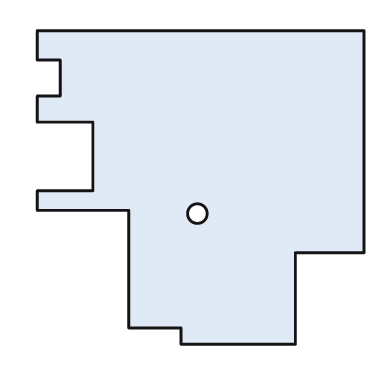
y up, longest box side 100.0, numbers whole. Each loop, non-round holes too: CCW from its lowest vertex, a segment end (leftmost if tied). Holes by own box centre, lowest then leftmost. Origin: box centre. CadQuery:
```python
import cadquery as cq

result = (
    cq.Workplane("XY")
    .moveTo(-6.0, -48.0)
    .lineTo(29.0, -48.0)
    .lineTo(29.0, -20.0)
    .lineTo(50.0, -20.0)
    .lineTo(50.0, 48.0)
    .lineTo(-50.0, 48.0)
    .lineTo(-50.0, 39.0)
    .lineTo(-43.0, 39.0)
    .lineTo(-43.0, 28.0)
    .lineTo(-50.0, 28.0)
    .lineTo(-50.0, 20.0)
    .lineTo(-33.0, 20.0)
    .lineTo(-33.0, -1.0)
    .lineTo(-50.0, -1.0)
    .lineTo(-50.0, -7.0)
    .lineTo(-22.0, -7.0)
    .lineTo(-22.0, -43.0)
    .lineTo(-6.0, -43.0)
    .close()
    .moveTo(-1.0, -8.0)
    .circle(3.0)
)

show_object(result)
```